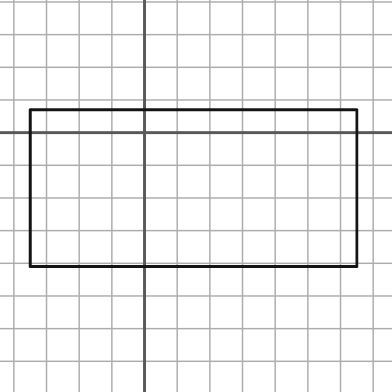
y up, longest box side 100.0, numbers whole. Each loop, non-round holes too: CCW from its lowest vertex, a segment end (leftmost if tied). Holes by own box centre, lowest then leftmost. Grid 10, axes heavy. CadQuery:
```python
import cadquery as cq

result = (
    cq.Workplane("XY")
    .moveTo(-35.0, -41.0)
    .lineTo(65.0, -41.0)
    .lineTo(65.0, 7.0)
    .lineTo(-35.0, 7.0)
    .close()
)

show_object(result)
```